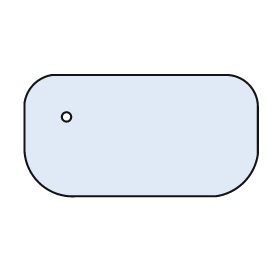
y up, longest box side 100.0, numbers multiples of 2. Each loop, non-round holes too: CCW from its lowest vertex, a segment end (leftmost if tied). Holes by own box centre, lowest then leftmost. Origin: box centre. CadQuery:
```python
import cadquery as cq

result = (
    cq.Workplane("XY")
    .moveTo(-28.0, -26.0)
    .lineTo(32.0, -26.0)
    .threePointArc((44.0, -20.0), (50.0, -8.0))
    .lineTo(50.0, 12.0)
    .threePointArc((46.0, 22.0), (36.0, 26.0))
    .lineTo(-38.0, 26.0)
    .threePointArc((-46.0, 22.0), (-50.0, 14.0))
    .lineTo(-50.0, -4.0)
    .threePointArc((-44.0, -20.0), (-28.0, -26.0))
    .close()
    .moveTo(-32.0, 8.0)
    .circle(2.0)
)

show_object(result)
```